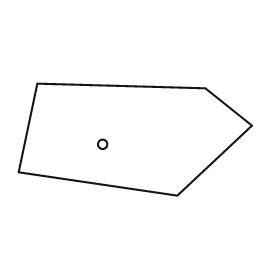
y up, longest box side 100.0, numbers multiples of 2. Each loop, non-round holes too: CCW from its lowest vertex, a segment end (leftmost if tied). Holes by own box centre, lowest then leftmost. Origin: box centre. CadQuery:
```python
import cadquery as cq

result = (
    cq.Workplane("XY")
    .moveTo(18.0, -24.0)
    .lineTo(50.0, 6.0)
    .lineTo(30.0, 22.0)
    .lineTo(-42.0, 24.0)
    .lineTo(-50.0, -14.0)
    .close()
    .moveTo(-14.0, -2.0)
    .circle(2.0)
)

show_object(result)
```